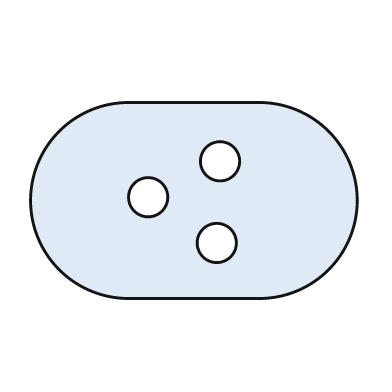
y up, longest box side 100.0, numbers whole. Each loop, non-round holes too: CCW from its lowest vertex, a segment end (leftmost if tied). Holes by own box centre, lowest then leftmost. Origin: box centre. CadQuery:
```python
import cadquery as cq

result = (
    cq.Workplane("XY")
    .moveTo(-20.0, -30.0)
    .lineTo(20.0, -30.0)
    .threePointArc((50.0, 0.0), (20.0, 30.0))
    .lineTo(-20.0, 30.0)
    .threePointArc((-50.0, 0.0), (-20.0, -30.0))
    .close()
    .moveTo(7.0, -13.0)
    .circle(6.0)
    .moveTo(-14.0, 1.0)
    .circle(6.0)
    .moveTo(8.0, 12.0)
    .circle(6.0)
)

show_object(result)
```